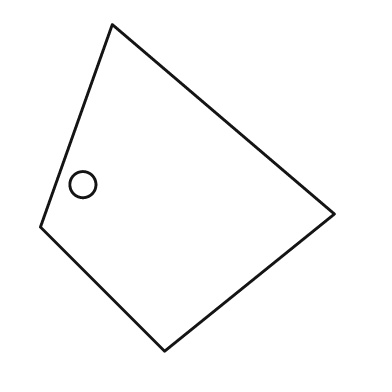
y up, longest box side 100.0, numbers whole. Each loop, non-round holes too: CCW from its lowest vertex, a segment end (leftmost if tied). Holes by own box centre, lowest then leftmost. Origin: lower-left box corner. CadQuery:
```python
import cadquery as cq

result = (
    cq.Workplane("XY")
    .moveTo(38.0, 0.0)
    .lineTo(90.0, 42.0)
    .lineTo(22.0, 100.0)
    .lineTo(0.0, 38.0)
    .close()
    .moveTo(13.0, 51.0)
    .circle(4.0)
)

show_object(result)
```